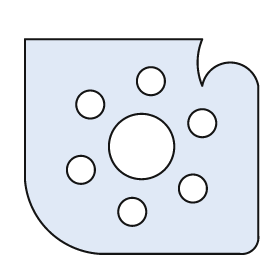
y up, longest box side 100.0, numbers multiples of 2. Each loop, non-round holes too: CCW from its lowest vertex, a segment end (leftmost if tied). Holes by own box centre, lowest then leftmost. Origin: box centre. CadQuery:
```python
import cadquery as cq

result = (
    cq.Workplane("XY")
    .moveTo(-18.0, -46.0)
    .lineTo(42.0, -46.0)
    .threePointArc((48.0, -44.0), (50.0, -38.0))
    .lineTo(50.0, 26.0)
    .threePointArc((38.0, 36.0), (26.0, 26.0))
    .threePointArc((24.0, 36.0), (26.0, 46.0))
    .lineTo(-50.0, 46.0)
    .lineTo(-50.0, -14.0)
    .threePointArc((-40.0, -36.0), (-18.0, -46.0))
    .close()
    .moveTo(-4.0, -28.0)
    .circle(6.0)
    .moveTo(22.0, -18.0)
    .circle(6.0)
    .moveTo(-26.0, -10.0)
    .circle(6.0)
    .moveTo(0.0, 0.0)
    .circle(14.0)
    .moveTo(26.0, 10.0)
    .circle(6.0)
    .moveTo(-22.0, 18.0)
    .circle(6.0)
    .moveTo(4.0, 28.0)
    .circle(6.0)
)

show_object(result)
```